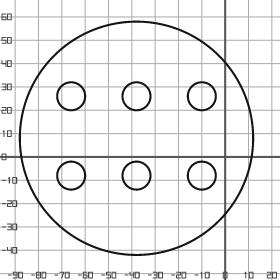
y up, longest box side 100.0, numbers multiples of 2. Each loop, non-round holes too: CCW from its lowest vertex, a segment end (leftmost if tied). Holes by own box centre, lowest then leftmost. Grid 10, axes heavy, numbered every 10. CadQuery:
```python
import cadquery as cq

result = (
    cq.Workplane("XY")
    .moveTo(-38.0, 8.0)
    .circle(50.0)
    .moveTo(-66.0, -8.0)
    .circle(6.0)
    .moveTo(-38.0, -8.0)
    .circle(6.0)
    .moveTo(-10.0, -8.0)
    .circle(6.0)
    .moveTo(-66.0, 26.0)
    .circle(6.0)
    .moveTo(-38.0, 26.0)
    .circle(6.0)
    .moveTo(-10.0, 26.0)
    .circle(6.0)
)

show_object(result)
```